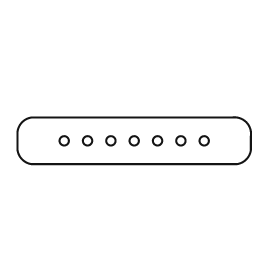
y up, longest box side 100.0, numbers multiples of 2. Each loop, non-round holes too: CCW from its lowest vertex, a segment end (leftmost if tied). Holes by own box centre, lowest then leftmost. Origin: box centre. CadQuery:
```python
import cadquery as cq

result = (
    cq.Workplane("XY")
    .moveTo(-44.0, -10.0)
    .lineTo(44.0, -10.0)
    .threePointArc((48.0, -8.0), (50.0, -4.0))
    .lineTo(50.0, 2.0)
    .threePointArc((48.0, 8.0), (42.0, 10.0))
    .lineTo(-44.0, 10.0)
    .threePointArc((-48.0, 8.0), (-50.0, 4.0))
    .lineTo(-50.0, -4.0)
    .threePointArc((-48.0, -8.0), (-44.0, -10.0))
    .close()
    .moveTo(-30.0, 0.0)
    .circle(2.0)
    .moveTo(-20.0, 0.0)
    .circle(2.0)
    .moveTo(-10.0, 0.0)
    .circle(2.0)
    .moveTo(0.0, 0.0)
    .circle(2.0)
    .moveTo(10.0, 0.0)
    .circle(2.0)
    .moveTo(20.0, 0.0)
    .circle(2.0)
    .moveTo(30.0, 0.0)
    .circle(2.0)
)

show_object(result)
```